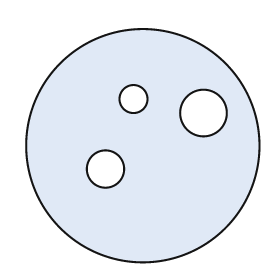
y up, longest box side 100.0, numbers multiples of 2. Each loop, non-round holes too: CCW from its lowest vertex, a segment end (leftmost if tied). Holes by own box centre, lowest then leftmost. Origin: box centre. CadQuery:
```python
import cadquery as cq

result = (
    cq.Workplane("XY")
    .moveTo(0.0, 0.0)
    .circle(50.0)
    .moveTo(-16.0, -10.0)
    .circle(8.0)
    .moveTo(26.0, 14.0)
    .circle(10.0)
    .moveTo(-4.0, 20.0)
    .circle(6.0)
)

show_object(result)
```